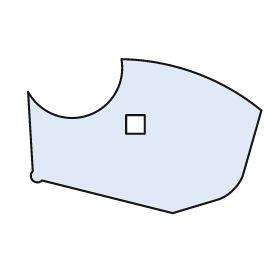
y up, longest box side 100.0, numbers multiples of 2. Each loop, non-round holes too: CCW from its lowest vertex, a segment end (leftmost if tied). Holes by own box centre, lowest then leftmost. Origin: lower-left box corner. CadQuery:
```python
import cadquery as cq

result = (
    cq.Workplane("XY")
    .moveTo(62.0, 0.0)
    .lineTo(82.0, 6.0)
    .threePointArc((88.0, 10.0), (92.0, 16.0))
    .lineTo(100.0, 44.0)
    .threePointArc((72.0, 60.0), (40.0, 66.0))
    .threePointArc((26.0, 42.0), (0.0, 52.0))
    .lineTo(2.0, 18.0)
    .threePointArc((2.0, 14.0), (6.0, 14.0))
    .close()
    .moveTo(42.0, 34.0)
    .lineTo(50.0, 34.0)
    .lineTo(50.0, 42.0)
    .lineTo(42.0, 42.0)
    .close()
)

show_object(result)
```